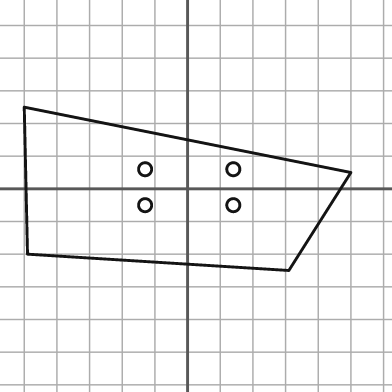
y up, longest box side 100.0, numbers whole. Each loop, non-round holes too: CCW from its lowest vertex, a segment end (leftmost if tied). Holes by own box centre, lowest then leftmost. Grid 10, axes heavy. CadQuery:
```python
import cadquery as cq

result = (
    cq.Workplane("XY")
    .moveTo(31.0, -25.0)
    .lineTo(50.0, 5.0)
    .lineTo(-50.0, 25.0)
    .lineTo(-49.0, -20.0)
    .close()
    .moveTo(-13.0, -5.0)
    .circle(2.0)
    .moveTo(14.0, -5.0)
    .circle(2.0)
    .moveTo(-13.0, 6.0)
    .circle(2.0)
    .moveTo(14.0, 6.0)
    .circle(2.0)
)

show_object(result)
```